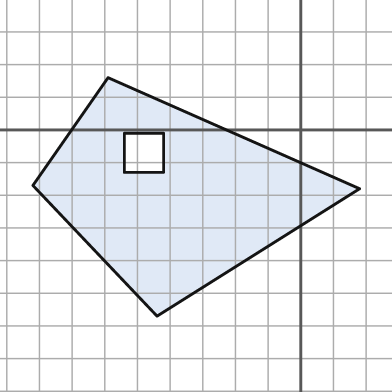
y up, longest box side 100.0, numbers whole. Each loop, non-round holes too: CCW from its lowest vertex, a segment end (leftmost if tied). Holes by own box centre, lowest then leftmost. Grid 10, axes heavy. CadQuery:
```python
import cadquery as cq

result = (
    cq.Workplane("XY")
    .moveTo(-44.0, -57.0)
    .lineTo(18.0, -18.0)
    .lineTo(-59.0, 16.0)
    .lineTo(-82.0, -17.0)
    .close()
    .moveTo(-54.0, -13.0)
    .lineTo(-42.0, -13.0)
    .lineTo(-42.0, -1.0)
    .lineTo(-54.0, -1.0)
    .close()
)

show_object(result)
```